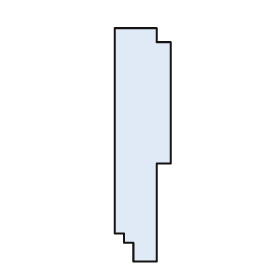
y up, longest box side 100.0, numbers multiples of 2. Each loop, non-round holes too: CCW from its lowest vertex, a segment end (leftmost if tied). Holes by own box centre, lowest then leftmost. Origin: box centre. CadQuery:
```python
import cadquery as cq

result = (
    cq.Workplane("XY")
    .moveTo(-4.0, -50.0)
    .lineTo(6.0, -50.0)
    .lineTo(6.0, -8.0)
    .lineTo(12.0, -8.0)
    .lineTo(12.0, 44.0)
    .lineTo(6.0, 44.0)
    .lineTo(6.0, 50.0)
    .lineTo(-12.0, 50.0)
    .lineTo(-12.0, -38.0)
    .lineTo(-8.0, -38.0)
    .lineTo(-8.0, -42.0)
    .lineTo(-4.0, -42.0)
    .close()
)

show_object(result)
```